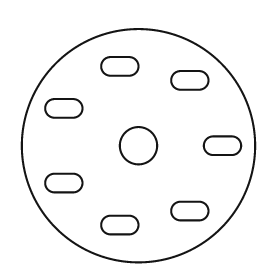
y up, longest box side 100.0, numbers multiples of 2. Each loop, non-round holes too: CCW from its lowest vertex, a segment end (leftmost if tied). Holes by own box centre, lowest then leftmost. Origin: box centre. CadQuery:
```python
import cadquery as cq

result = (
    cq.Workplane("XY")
    .moveTo(0.0, 0.0)
    .circle(50.0)
    .moveTo(-12.0, -38.0)
    .lineTo(-4.0, -38.0)
    .threePointArc((0.0, -34.0), (-4.0, -30.0))
    .lineTo(-12.0, -30.0)
    .threePointArc((-16.0, -34.0), (-12.0, -38.0))
    .close()
    .moveTo(18.0, -32.0)
    .lineTo(26.0, -32.0)
    .threePointArc((30.0, -28.0), (26.0, -24.0))
    .lineTo(18.0, -24.0)
    .threePointArc((14.0, -28.0), (18.0, -32.0))
    .close()
    .moveTo(-36.0, -20.0)
    .lineTo(-28.0, -20.0)
    .threePointArc((-24.0, -16.0), (-28.0, -12.0))
    .lineTo(-36.0, -12.0)
    .threePointArc((-40.0, -16.0), (-36.0, -20.0))
    .close()
    .moveTo(0.0, 0.0)
    .circle(8.0)
    .moveTo(32.0, -4.0)
    .lineTo(40.0, -4.0)
    .threePointArc((44.0, 0.0), (40.0, 4.0))
    .lineTo(32.0, 4.0)
    .threePointArc((28.0, 0.0), (32.0, -4.0))
    .close()
    .moveTo(-36.0, 12.0)
    .lineTo(-28.0, 12.0)
    .threePointArc((-24.0, 16.0), (-28.0, 20.0))
    .lineTo(-36.0, 20.0)
    .threePointArc((-40.0, 16.0), (-36.0, 12.0))
    .close()
    .moveTo(18.0, 24.0)
    .lineTo(26.0, 24.0)
    .threePointArc((30.0, 28.0), (26.0, 32.0))
    .lineTo(18.0, 32.0)
    .threePointArc((14.0, 28.0), (18.0, 24.0))
    .close()
    .moveTo(-12.0, 30.0)
    .lineTo(-4.0, 30.0)
    .threePointArc((0.0, 34.0), (-4.0, 38.0))
    .lineTo(-12.0, 38.0)
    .threePointArc((-16.0, 34.0), (-12.0, 30.0))
    .close()
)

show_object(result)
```